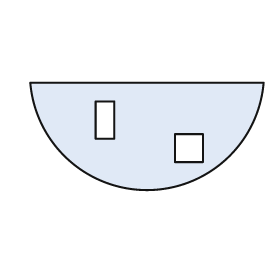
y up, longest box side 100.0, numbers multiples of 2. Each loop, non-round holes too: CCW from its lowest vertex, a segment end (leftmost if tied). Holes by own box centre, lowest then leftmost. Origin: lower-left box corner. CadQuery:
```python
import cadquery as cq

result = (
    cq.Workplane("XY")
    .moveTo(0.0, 46.0)
    .threePointArc((50.0, 0.0), (100.0, 46.0))
    .close()
    .moveTo(62.0, 12.0)
    .lineTo(74.0, 12.0)
    .lineTo(74.0, 24.0)
    .lineTo(62.0, 24.0)
    .close()
    .moveTo(28.0, 22.0)
    .lineTo(36.0, 22.0)
    .lineTo(36.0, 38.0)
    .lineTo(28.0, 38.0)
    .close()
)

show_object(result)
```